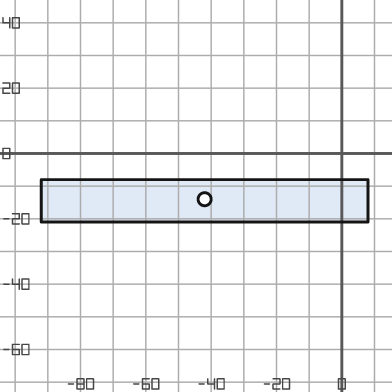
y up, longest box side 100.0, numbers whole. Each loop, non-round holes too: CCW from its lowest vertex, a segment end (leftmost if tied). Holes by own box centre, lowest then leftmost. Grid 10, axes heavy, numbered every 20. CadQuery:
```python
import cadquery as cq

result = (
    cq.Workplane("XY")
    .moveTo(-92.0, -21.0)
    .lineTo(8.0, -21.0)
    .lineTo(8.0, -8.0)
    .lineTo(-92.0, -8.0)
    .close()
    .moveTo(-42.0, -14.0)
    .circle(2.0)
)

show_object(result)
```